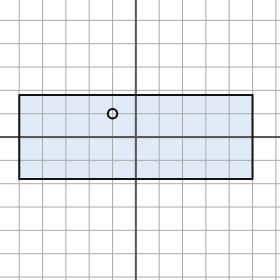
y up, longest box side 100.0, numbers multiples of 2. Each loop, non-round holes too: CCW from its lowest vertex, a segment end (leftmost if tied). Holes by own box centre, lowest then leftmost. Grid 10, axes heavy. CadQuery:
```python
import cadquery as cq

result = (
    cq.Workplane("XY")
    .moveTo(-50.0, -18.0)
    .lineTo(50.0, -18.0)
    .lineTo(50.0, 18.0)
    .lineTo(-50.0, 18.0)
    .close()
    .moveTo(-10.0, 10.0)
    .circle(2.0)
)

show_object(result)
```